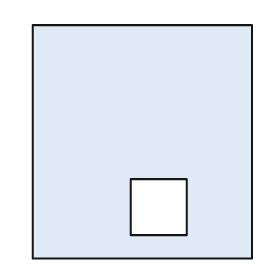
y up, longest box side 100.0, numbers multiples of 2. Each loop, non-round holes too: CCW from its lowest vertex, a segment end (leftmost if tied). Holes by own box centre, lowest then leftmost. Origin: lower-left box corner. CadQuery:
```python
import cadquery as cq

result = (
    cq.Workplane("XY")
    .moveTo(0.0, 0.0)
    .lineTo(94.0, 0.0)
    .lineTo(94.0, 100.0)
    .lineTo(0.0, 100.0)
    .close()
    .moveTo(42.0, 10.0)
    .lineTo(66.0, 10.0)
    .lineTo(66.0, 34.0)
    .lineTo(42.0, 34.0)
    .close()
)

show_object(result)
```